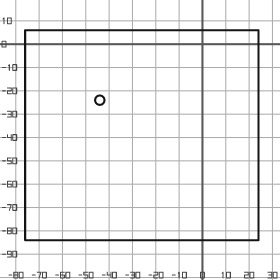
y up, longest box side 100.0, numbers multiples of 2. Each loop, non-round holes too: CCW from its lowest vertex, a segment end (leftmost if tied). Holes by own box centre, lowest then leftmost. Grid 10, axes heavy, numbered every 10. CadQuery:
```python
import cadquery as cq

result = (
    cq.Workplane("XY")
    .moveTo(-76.0, -84.0)
    .lineTo(24.0, -84.0)
    .lineTo(24.0, 6.0)
    .lineTo(-76.0, 6.0)
    .close()
    .moveTo(-44.0, -24.0)
    .circle(2.0)
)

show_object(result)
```